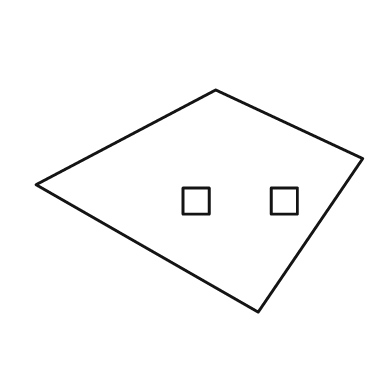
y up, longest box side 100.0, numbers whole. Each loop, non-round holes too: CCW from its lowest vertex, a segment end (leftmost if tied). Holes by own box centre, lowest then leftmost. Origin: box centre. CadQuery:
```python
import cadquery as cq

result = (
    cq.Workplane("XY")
    .moveTo(18.0, -34.0)
    .lineTo(50.0, 13.0)
    .lineTo(5.0, 34.0)
    .lineTo(-50.0, 5.0)
    .close()
    .moveTo(-5.0, -4.0)
    .lineTo(3.0, -4.0)
    .lineTo(3.0, 4.0)
    .lineTo(-5.0, 4.0)
    .close()
    .moveTo(22.0, -4.0)
    .lineTo(30.0, -4.0)
    .lineTo(30.0, 4.0)
    .lineTo(22.0, 4.0)
    .close()
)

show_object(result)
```